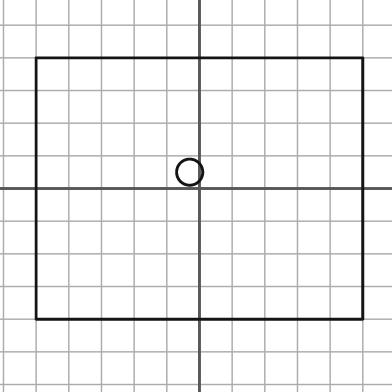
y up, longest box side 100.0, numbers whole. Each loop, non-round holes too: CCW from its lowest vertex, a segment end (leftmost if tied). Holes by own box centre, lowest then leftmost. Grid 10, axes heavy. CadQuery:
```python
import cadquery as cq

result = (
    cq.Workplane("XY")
    .moveTo(-50.0, -40.0)
    .lineTo(50.0, -40.0)
    .lineTo(50.0, 40.0)
    .lineTo(-50.0, 40.0)
    .close()
    .moveTo(-3.0, 5.0)
    .circle(4.0)
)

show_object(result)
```